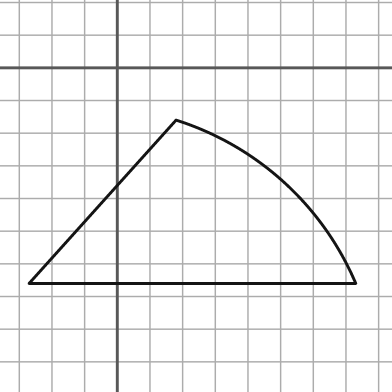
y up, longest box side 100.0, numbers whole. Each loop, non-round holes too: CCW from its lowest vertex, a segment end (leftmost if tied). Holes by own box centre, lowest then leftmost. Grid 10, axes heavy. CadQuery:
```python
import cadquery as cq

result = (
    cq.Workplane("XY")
    .moveTo(-27.0, -66.0)
    .lineTo(73.0, -66.0)
    .threePointArc((51.0, -35.0), (18.0, -16.0))
    .close()
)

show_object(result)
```